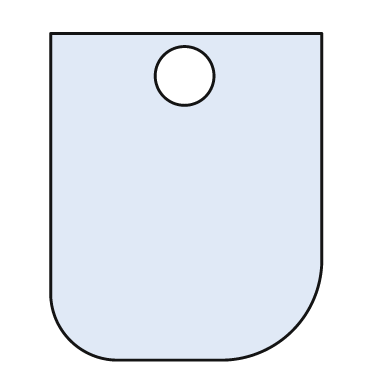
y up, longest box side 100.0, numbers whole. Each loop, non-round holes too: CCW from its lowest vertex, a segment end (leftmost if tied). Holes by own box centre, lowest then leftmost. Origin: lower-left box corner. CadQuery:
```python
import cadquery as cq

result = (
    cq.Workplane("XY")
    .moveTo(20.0, 0.0)
    .lineTo(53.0, 0.0)
    .threePointArc((74.0, 9.0), (83.0, 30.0))
    .lineTo(83.0, 100.0)
    .lineTo(0.0, 100.0)
    .lineTo(0.0, 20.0)
    .threePointArc((6.0, 6.0), (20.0, 0.0))
    .close()
    .moveTo(41.0, 87.0)
    .circle(9.0)
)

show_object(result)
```